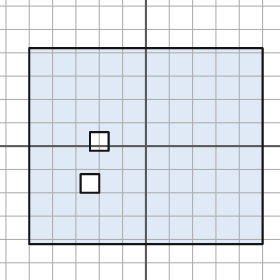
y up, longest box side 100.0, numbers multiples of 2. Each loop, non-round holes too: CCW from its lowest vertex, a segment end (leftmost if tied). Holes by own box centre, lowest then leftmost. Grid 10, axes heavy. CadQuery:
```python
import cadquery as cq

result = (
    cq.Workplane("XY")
    .moveTo(-50.0, -42.0)
    .lineTo(50.0, -42.0)
    .lineTo(50.0, 42.0)
    .lineTo(-50.0, 42.0)
    .close()
    .moveTo(-28.0, -20.0)
    .lineTo(-20.0, -20.0)
    .lineTo(-20.0, -12.0)
    .lineTo(-28.0, -12.0)
    .close()
    .moveTo(-24.0, -2.0)
    .lineTo(-16.0, -2.0)
    .lineTo(-16.0, 6.0)
    .lineTo(-24.0, 6.0)
    .close()
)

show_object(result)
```